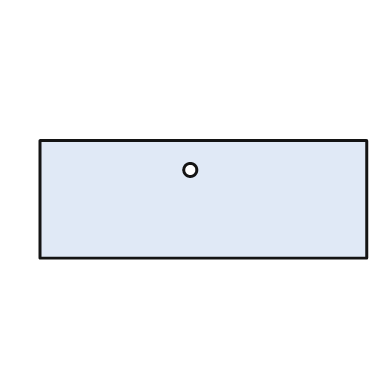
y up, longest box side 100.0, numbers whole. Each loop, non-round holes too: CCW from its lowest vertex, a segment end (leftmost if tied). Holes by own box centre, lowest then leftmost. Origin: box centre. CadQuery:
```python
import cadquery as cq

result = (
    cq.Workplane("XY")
    .moveTo(-50.0, -18.0)
    .lineTo(50.0, -18.0)
    .lineTo(50.0, 18.0)
    .lineTo(-50.0, 18.0)
    .close()
    .moveTo(-4.0, 9.0)
    .circle(2.0)
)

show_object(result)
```